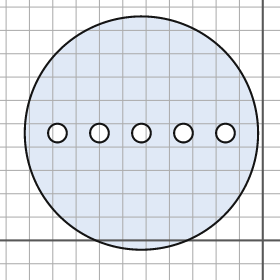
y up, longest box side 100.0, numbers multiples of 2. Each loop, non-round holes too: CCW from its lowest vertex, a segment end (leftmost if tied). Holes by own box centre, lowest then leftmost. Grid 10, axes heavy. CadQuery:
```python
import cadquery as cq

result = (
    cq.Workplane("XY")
    .moveTo(-52.0, 46.0)
    .circle(50.0)
    .moveTo(-88.0, 46.0)
    .circle(4.0)
    .moveTo(-70.0, 46.0)
    .circle(4.0)
    .moveTo(-52.0, 46.0)
    .circle(4.0)
    .moveTo(-34.0, 46.0)
    .circle(4.0)
    .moveTo(-16.0, 46.0)
    .circle(4.0)
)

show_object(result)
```